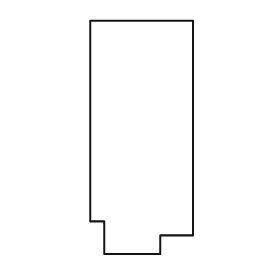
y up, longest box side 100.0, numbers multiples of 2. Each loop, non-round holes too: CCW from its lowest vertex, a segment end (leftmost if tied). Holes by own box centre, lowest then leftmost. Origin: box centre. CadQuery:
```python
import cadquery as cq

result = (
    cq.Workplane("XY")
    .moveTo(-16.0, -50.0)
    .lineTo(8.0, -50.0)
    .lineTo(8.0, -42.0)
    .lineTo(22.0, -42.0)
    .lineTo(22.0, 50.0)
    .lineTo(-22.0, 50.0)
    .lineTo(-22.0, -36.0)
    .lineTo(-16.0, -36.0)
    .close()
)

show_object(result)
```